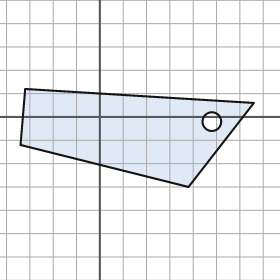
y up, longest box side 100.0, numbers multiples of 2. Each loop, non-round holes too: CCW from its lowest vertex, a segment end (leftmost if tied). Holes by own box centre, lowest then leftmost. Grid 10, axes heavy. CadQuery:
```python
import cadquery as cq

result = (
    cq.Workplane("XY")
    .moveTo(38.0, -30.0)
    .lineTo(66.0, 6.0)
    .lineTo(-32.0, 12.0)
    .lineTo(-34.0, -12.0)
    .close()
    .moveTo(48.0, -2.0)
    .circle(4.0)
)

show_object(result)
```